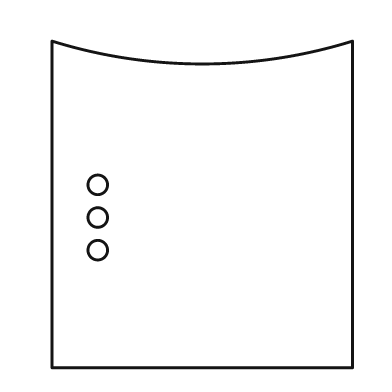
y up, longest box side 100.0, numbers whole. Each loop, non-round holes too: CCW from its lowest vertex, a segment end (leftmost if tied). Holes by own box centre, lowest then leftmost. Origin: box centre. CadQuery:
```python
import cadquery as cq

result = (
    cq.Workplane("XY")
    .moveTo(-46.0, -50.0)
    .lineTo(46.0, -50.0)
    .lineTo(46.0, 50.0)
    .threePointArc((0.0, 43.0), (-46.0, 50.0))
    .close()
    .moveTo(-32.0, -14.0)
    .circle(3.0)
    .moveTo(-32.0, -4.0)
    .circle(3.0)
    .moveTo(-32.0, 6.0)
    .circle(3.0)
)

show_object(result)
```